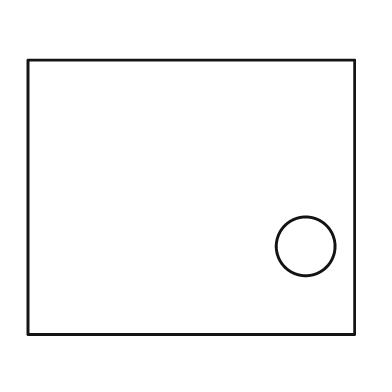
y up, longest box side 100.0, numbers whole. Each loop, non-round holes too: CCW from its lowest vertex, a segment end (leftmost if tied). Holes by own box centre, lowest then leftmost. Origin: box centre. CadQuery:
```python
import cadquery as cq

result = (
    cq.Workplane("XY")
    .moveTo(-50.0, -42.0)
    .lineTo(50.0, -42.0)
    .lineTo(50.0, 42.0)
    .lineTo(-50.0, 42.0)
    .close()
    .moveTo(35.0, -15.0)
    .circle(9.0)
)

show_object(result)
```